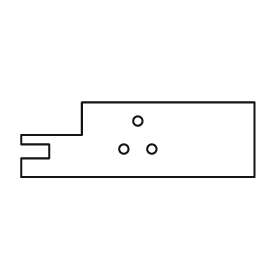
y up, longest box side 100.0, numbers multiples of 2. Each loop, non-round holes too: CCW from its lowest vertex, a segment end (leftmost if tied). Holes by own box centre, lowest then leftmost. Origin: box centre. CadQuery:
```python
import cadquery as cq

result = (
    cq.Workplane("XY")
    .moveTo(-50.0, -16.0)
    .lineTo(50.0, -16.0)
    .lineTo(50.0, 16.0)
    .lineTo(-24.0, 16.0)
    .lineTo(-24.0, 2.0)
    .lineTo(-50.0, 2.0)
    .lineTo(-50.0, -2.0)
    .lineTo(-38.0, -2.0)
    .lineTo(-38.0, -8.0)
    .lineTo(-50.0, -8.0)
    .close()
    .moveTo(-6.0, -4.0)
    .circle(2.0)
    .moveTo(6.0, -4.0)
    .circle(2.0)
    .moveTo(0.0, 8.0)
    .circle(2.0)
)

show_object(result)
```